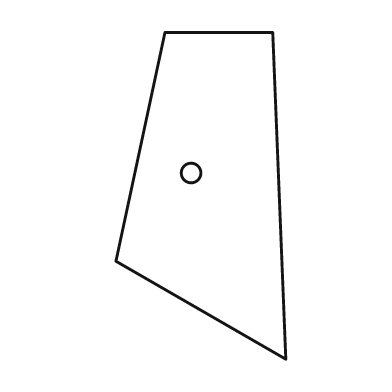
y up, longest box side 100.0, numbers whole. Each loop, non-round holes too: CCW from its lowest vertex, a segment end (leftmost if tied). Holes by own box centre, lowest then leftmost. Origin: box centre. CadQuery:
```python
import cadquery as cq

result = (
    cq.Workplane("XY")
    .moveTo(26.0, -50.0)
    .lineTo(22.0, 50.0)
    .lineTo(-11.0, 50.0)
    .lineTo(-26.0, -20.0)
    .close()
    .moveTo(-3.0, 7.0)
    .circle(3.0)
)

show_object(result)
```